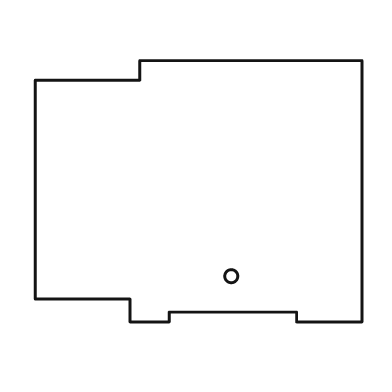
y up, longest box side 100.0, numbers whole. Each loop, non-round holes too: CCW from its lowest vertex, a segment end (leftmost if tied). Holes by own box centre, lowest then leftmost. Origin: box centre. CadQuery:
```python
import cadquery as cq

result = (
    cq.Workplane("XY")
    .moveTo(-21.0, -40.0)
    .lineTo(-9.0, -40.0)
    .lineTo(-9.0, -37.0)
    .lineTo(30.0, -37.0)
    .lineTo(30.0, -40.0)
    .lineTo(50.0, -40.0)
    .lineTo(50.0, 40.0)
    .lineTo(-18.0, 40.0)
    .lineTo(-18.0, 34.0)
    .lineTo(-50.0, 34.0)
    .lineTo(-50.0, -33.0)
    .lineTo(-21.0, -33.0)
    .close()
    .moveTo(10.0, -26.0)
    .circle(2.0)
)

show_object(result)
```